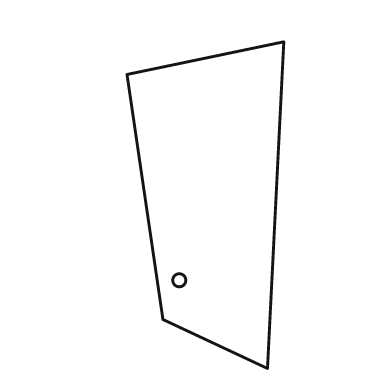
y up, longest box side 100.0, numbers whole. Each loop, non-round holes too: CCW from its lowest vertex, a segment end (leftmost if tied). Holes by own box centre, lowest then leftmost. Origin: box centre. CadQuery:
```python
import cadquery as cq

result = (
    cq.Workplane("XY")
    .moveTo(19.0, -50.0)
    .lineTo(24.0, 50.0)
    .lineTo(-24.0, 40.0)
    .lineTo(-13.0, -35.0)
    .close()
    .moveTo(-8.0, -23.0)
    .circle(2.0)
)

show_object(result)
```